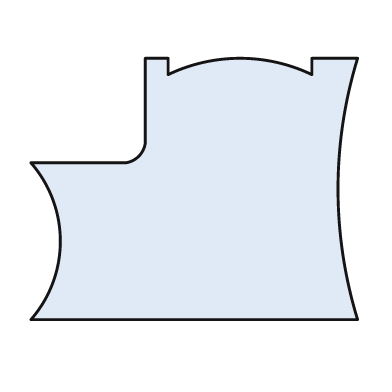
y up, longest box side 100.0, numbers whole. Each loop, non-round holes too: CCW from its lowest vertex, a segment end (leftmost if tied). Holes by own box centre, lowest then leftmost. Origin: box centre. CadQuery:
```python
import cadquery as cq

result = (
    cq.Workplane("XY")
    .moveTo(-50.0, -40.0)
    .lineTo(50.0, -40.0)
    .threePointArc((44.0, 0.0), (50.0, 40.0))
    .lineTo(36.0, 40.0)
    .lineTo(36.0, 35.0)
    .threePointArc((14.0, 40.0), (-8.0, 35.0))
    .lineTo(-8.0, 40.0)
    .lineTo(-15.0, 40.0)
    .lineTo(-15.0, 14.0)
    .threePointArc((-17.0, 10.0), (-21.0, 8.0))
    .lineTo(-50.0, 8.0)
    .threePointArc((-41.0, -16.0), (-50.0, -40.0))
    .close()
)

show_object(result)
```